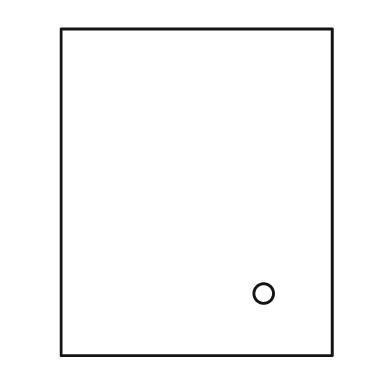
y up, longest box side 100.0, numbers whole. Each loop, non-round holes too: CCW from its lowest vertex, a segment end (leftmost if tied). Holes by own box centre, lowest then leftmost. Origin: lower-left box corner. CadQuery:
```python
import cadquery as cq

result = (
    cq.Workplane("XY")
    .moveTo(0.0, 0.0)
    .lineTo(83.0, 0.0)
    .lineTo(83.0, 100.0)
    .lineTo(0.0, 100.0)
    .close()
    .moveTo(62.0, 19.0)
    .circle(3.0)
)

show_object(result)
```